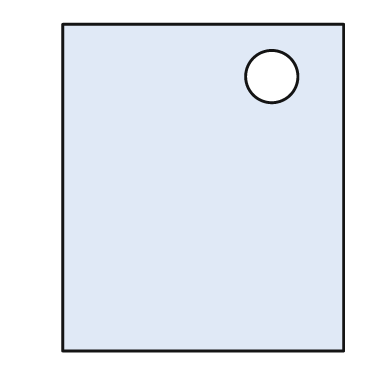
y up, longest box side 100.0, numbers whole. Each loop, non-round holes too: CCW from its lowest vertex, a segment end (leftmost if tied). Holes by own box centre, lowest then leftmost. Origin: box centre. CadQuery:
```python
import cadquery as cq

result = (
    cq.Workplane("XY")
    .moveTo(-43.0, -50.0)
    .lineTo(43.0, -50.0)
    .lineTo(43.0, 50.0)
    .lineTo(-43.0, 50.0)
    .close()
    .moveTo(21.0, 34.0)
    .circle(8.0)
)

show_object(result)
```